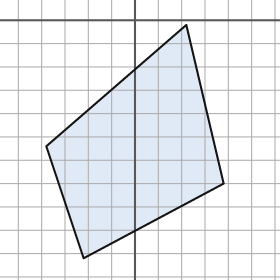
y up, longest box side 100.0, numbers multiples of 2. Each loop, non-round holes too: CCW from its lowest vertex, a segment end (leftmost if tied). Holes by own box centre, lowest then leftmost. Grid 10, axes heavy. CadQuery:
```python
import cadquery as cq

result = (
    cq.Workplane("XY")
    .moveTo(-22.0, -102.0)
    .lineTo(38.0, -70.0)
    .lineTo(22.0, -2.0)
    .lineTo(-38.0, -54.0)
    .close()
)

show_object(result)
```